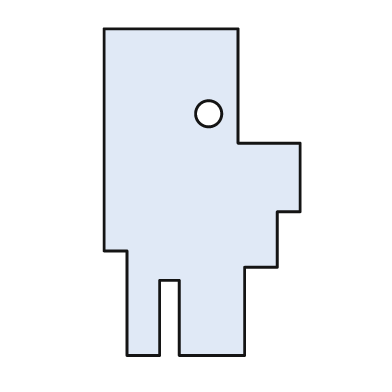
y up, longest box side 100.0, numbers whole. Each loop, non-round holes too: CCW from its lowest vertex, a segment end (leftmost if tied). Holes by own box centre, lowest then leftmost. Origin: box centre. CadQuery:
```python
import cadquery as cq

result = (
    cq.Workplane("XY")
    .moveTo(-23.0, -50.0)
    .lineTo(-13.0, -50.0)
    .lineTo(-13.0, -27.0)
    .lineTo(-7.0, -27.0)
    .lineTo(-7.0, -50.0)
    .lineTo(13.0, -50.0)
    .lineTo(13.0, -23.0)
    .lineTo(23.0, -23.0)
    .lineTo(23.0, -6.0)
    .lineTo(30.0, -6.0)
    .lineTo(30.0, 15.0)
    .lineTo(11.0, 15.0)
    .lineTo(11.0, 50.0)
    .lineTo(-30.0, 50.0)
    .lineTo(-30.0, -18.0)
    .lineTo(-23.0, -18.0)
    .close()
    .moveTo(2.0, 24.0)
    .circle(4.0)
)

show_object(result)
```